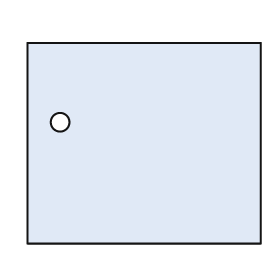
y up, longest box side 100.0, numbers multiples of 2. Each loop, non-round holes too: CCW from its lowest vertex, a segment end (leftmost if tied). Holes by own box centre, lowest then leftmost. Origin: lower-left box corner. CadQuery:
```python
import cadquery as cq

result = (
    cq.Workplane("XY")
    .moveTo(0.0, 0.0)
    .lineTo(100.0, 0.0)
    .lineTo(100.0, 86.0)
    .lineTo(0.0, 86.0)
    .close()
    .moveTo(14.0, 52.0)
    .circle(4.0)
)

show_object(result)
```